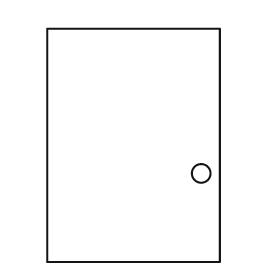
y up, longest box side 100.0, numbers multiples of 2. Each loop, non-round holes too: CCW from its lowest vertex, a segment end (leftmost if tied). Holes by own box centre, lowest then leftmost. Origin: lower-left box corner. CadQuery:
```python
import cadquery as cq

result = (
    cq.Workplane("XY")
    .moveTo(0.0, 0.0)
    .lineTo(74.0, 0.0)
    .lineTo(74.0, 100.0)
    .lineTo(0.0, 100.0)
    .close()
    .moveTo(66.0, 38.0)
    .circle(4.0)
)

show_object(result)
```